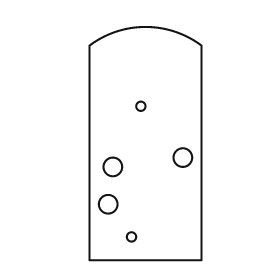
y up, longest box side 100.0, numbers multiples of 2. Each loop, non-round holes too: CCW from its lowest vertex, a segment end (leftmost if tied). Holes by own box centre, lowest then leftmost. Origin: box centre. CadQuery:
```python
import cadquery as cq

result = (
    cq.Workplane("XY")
    .moveTo(-24.0, -50.0)
    .lineTo(24.0, -50.0)
    .lineTo(24.0, 42.0)
    .threePointArc((0.0, 50.0), (-24.0, 42.0))
    .close()
    .moveTo(-6.0, -40.0)
    .circle(2.0)
    .moveTo(-16.0, -26.0)
    .circle(4.0)
    .moveTo(-14.0, -10.0)
    .circle(4.0)
    .moveTo(16.0, -6.0)
    .circle(4.0)
    .moveTo(-2.0, 16.0)
    .circle(2.0)
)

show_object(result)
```